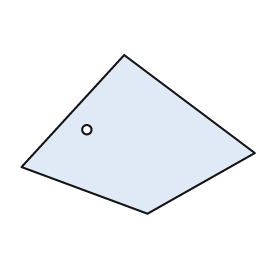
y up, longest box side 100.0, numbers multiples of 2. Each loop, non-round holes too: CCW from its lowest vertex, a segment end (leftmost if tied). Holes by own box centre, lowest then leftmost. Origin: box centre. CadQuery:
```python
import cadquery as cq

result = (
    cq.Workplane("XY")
    .moveTo(4.0, -34.0)
    .lineTo(50.0, -8.0)
    .lineTo(-6.0, 34.0)
    .lineTo(-50.0, -14.0)
    .close()
    .moveTo(-22.0, 2.0)
    .circle(2.0)
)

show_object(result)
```